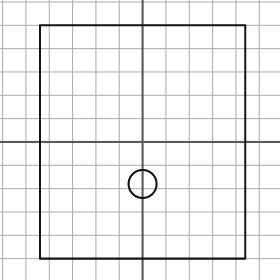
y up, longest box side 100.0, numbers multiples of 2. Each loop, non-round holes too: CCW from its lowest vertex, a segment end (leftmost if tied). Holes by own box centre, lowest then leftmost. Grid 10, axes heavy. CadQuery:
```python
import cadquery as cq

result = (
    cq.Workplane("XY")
    .moveTo(-44.0, -50.0)
    .lineTo(44.0, -50.0)
    .lineTo(44.0, 50.0)
    .lineTo(-44.0, 50.0)
    .close()
    .moveTo(0.0, -18.0)
    .circle(6.0)
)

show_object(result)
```